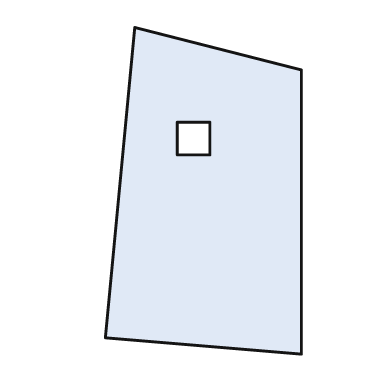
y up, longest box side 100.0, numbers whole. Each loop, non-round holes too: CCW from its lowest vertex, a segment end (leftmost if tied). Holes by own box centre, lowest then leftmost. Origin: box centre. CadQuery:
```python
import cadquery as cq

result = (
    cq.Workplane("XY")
    .moveTo(30.0, -50.0)
    .lineTo(30.0, 37.0)
    .lineTo(-21.0, 50.0)
    .lineTo(-30.0, -45.0)
    .close()
    .moveTo(-8.0, 11.0)
    .lineTo(2.0, 11.0)
    .lineTo(2.0, 21.0)
    .lineTo(-8.0, 21.0)
    .close()
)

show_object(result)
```